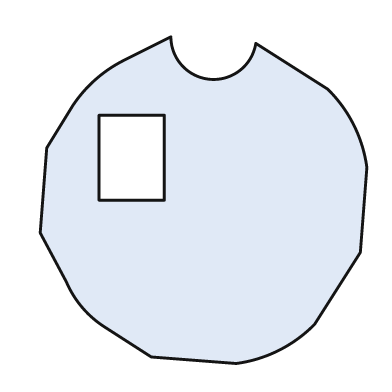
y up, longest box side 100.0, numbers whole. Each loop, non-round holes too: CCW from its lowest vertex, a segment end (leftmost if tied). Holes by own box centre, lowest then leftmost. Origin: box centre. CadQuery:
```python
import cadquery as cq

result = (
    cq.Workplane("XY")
    .moveTo(10.0, -50.0)
    .threePointArc((23.0, -46.0), (34.0, -38.0))
    .lineTo(48.0, -16.0)
    .lineTo(50.0, 10.0)
    .threePointArc((46.0, 23.0), (38.0, 34.0))
    .lineTo(16.0, 48.0)
    .threePointArc((2.0, 37.0), (-10.0, 50.0))
    .lineTo(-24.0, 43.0)
    .threePointArc((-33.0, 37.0), (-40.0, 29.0))
    .lineTo(-48.0, 16.0)
    .lineTo(-50.0, -10.0)
    .lineTo(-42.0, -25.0)
    .threePointArc((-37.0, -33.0), (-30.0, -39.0))
    .lineTo(-16.0, -48.0)
    .close()
    .moveTo(-32.0, 0.0)
    .lineTo(-12.0, 0.0)
    .lineTo(-12.0, 26.0)
    .lineTo(-32.0, 26.0)
    .close()
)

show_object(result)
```